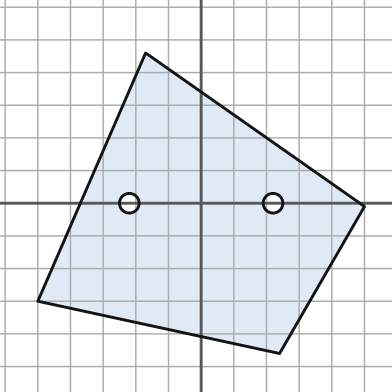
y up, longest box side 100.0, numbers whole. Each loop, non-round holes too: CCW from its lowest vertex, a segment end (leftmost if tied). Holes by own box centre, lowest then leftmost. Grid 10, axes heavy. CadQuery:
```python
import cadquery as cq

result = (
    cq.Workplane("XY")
    .moveTo(24.0, -46.0)
    .lineTo(50.0, -1.0)
    .lineTo(-17.0, 46.0)
    .lineTo(-50.0, -30.0)
    .close()
    .moveTo(-22.0, 0.0)
    .circle(3.0)
    .moveTo(22.0, 0.0)
    .circle(3.0)
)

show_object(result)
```